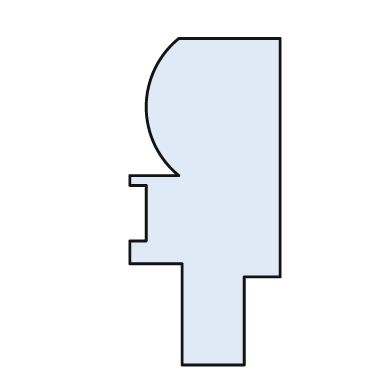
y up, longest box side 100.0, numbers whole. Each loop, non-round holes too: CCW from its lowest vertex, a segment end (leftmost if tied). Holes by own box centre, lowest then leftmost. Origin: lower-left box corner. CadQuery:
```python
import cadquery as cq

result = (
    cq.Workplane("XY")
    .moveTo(16.0, 0.0)
    .lineTo(35.0, 0.0)
    .lineTo(35.0, 27.0)
    .lineTo(46.0, 27.0)
    .lineTo(46.0, 100.0)
    .lineTo(15.0, 100.0)
    .threePointArc((5.0, 79.0), (15.0, 58.0))
    .lineTo(0.0, 58.0)
    .lineTo(0.0, 55.0)
    .lineTo(5.0, 55.0)
    .lineTo(5.0, 38.0)
    .lineTo(0.0, 38.0)
    .lineTo(0.0, 31.0)
    .lineTo(16.0, 31.0)
    .close()
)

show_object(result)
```